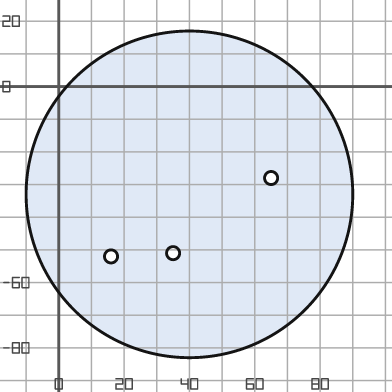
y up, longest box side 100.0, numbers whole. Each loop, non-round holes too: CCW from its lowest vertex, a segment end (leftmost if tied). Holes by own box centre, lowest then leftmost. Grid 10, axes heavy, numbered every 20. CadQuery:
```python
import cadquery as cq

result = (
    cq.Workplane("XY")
    .moveTo(40.0, -33.0)
    .circle(50.0)
    .moveTo(16.0, -52.0)
    .circle(2.0)
    .moveTo(35.0, -51.0)
    .circle(2.0)
    .moveTo(65.0, -28.0)
    .circle(2.0)
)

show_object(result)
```